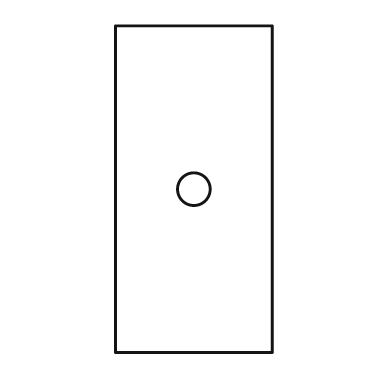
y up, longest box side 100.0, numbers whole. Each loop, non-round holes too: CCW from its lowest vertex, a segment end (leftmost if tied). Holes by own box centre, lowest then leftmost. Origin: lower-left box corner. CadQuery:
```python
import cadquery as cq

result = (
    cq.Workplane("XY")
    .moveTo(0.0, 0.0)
    .lineTo(48.0, 0.0)
    .lineTo(48.0, 100.0)
    .lineTo(0.0, 100.0)
    .close()
    .moveTo(24.0, 50.0)
    .circle(5.0)
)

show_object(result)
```